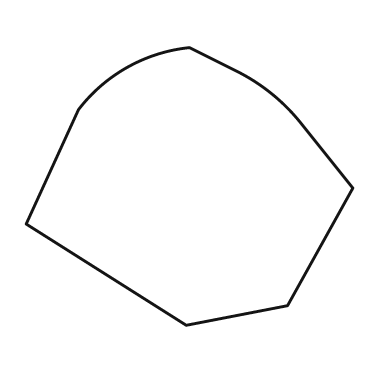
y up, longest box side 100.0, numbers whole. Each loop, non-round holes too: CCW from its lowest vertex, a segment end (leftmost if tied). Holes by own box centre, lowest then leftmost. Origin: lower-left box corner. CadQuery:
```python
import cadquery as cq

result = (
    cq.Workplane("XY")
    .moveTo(49.0, 0.0)
    .lineTo(80.0, 6.0)
    .lineTo(100.0, 42.0)
    .lineTo(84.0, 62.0)
    .threePointArc((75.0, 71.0), (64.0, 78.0))
    .lineTo(50.0, 85.0)
    .threePointArc((31.0, 79.0), (16.0, 66.0))
    .lineTo(0.0, 31.0)
    .close()
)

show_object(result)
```